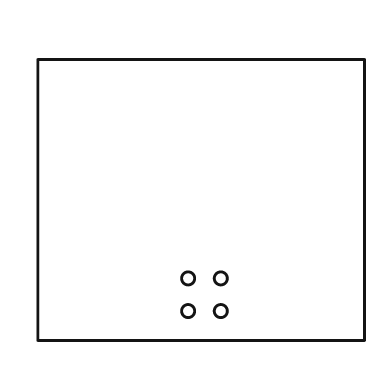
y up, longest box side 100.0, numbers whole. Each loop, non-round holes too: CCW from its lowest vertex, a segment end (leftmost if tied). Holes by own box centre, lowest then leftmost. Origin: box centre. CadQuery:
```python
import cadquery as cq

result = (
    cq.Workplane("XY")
    .moveTo(-50.0, -43.0)
    .lineTo(50.0, -43.0)
    .lineTo(50.0, 43.0)
    .lineTo(-50.0, 43.0)
    .close()
    .moveTo(-4.0, -34.0)
    .circle(2.0)
    .moveTo(6.0, -34.0)
    .circle(2.0)
    .moveTo(-4.0, -24.0)
    .circle(2.0)
    .moveTo(6.0, -24.0)
    .circle(2.0)
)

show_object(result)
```